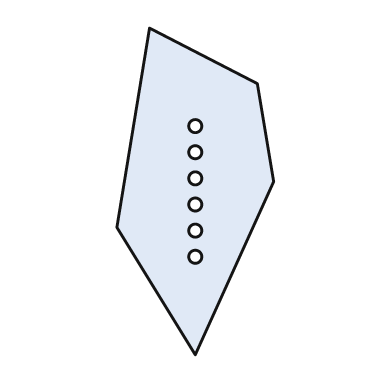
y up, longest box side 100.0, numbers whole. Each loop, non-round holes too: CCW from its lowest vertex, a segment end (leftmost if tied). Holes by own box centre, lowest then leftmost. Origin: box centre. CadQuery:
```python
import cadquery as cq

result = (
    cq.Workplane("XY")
    .moveTo(0.0, -50.0)
    .lineTo(24.0, 3.0)
    .lineTo(19.0, 33.0)
    .lineTo(-14.0, 50.0)
    .lineTo(-24.0, -11.0)
    .close()
    .moveTo(0.0, -20.0)
    .circle(2.0)
    .moveTo(0.0, -12.0)
    .circle(2.0)
    .moveTo(0.0, -4.0)
    .circle(2.0)
    .moveTo(0.0, 4.0)
    .circle(2.0)
    .moveTo(0.0, 12.0)
    .circle(2.0)
    .moveTo(0.0, 20.0)
    .circle(2.0)
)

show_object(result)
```